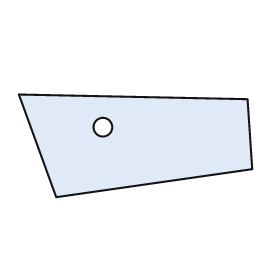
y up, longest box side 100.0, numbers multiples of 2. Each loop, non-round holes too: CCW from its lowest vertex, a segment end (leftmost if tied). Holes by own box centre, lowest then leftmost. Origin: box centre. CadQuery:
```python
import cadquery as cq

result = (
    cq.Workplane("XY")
    .moveTo(-34.0, -22.0)
    .lineTo(50.0, -10.0)
    .lineTo(48.0, 20.0)
    .lineTo(-50.0, 22.0)
    .close()
    .moveTo(-14.0, 8.0)
    .circle(4.0)
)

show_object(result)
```